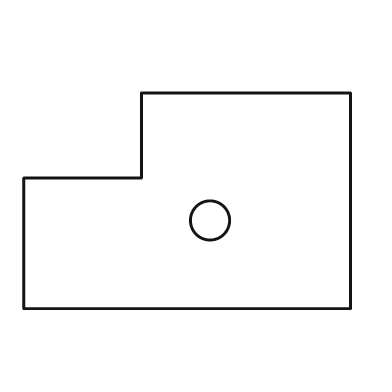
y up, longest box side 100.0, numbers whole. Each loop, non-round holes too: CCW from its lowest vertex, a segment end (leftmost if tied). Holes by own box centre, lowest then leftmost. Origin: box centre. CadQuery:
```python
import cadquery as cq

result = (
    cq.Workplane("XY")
    .moveTo(-50.0, -33.0)
    .lineTo(50.0, -33.0)
    .lineTo(50.0, 33.0)
    .lineTo(-14.0, 33.0)
    .lineTo(-14.0, 7.0)
    .lineTo(-50.0, 7.0)
    .close()
    .moveTo(7.0, -6.0)
    .circle(6.0)
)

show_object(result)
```